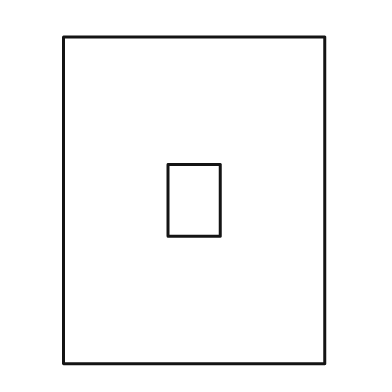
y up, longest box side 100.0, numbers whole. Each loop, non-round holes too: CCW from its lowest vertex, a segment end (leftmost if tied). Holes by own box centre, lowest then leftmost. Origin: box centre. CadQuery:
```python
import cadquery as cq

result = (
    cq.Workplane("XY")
    .moveTo(-40.0, -50.0)
    .lineTo(40.0, -50.0)
    .lineTo(40.0, 50.0)
    .lineTo(-40.0, 50.0)
    .close()
    .moveTo(-8.0, -11.0)
    .lineTo(8.0, -11.0)
    .lineTo(8.0, 11.0)
    .lineTo(-8.0, 11.0)
    .close()
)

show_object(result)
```